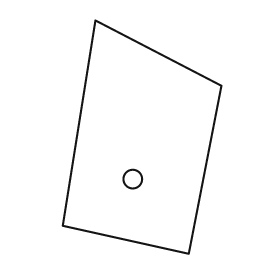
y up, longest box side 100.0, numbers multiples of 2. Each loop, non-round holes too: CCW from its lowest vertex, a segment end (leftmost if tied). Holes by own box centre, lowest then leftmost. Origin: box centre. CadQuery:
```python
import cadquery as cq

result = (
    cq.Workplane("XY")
    .moveTo(20.0, -50.0)
    .lineTo(34.0, 22.0)
    .lineTo(-20.0, 50.0)
    .lineTo(-34.0, -38.0)
    .close()
    .moveTo(-4.0, -18.0)
    .circle(4.0)
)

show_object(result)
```